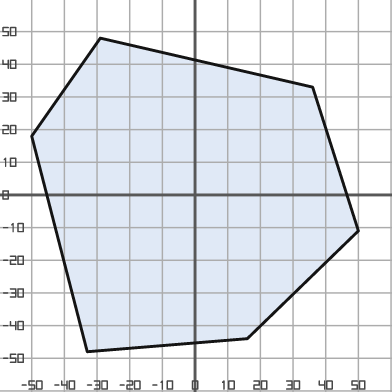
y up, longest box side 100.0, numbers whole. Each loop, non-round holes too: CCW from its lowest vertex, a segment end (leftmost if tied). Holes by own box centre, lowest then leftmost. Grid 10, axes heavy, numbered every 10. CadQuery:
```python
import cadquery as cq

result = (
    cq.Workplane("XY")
    .moveTo(-33.0, -48.0)
    .lineTo(16.0, -44.0)
    .lineTo(50.0, -11.0)
    .lineTo(36.0, 33.0)
    .lineTo(-29.0, 48.0)
    .lineTo(-50.0, 18.0)
    .close()
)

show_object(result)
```